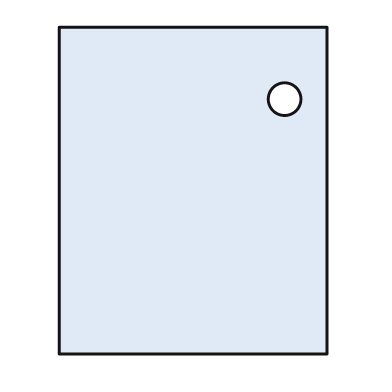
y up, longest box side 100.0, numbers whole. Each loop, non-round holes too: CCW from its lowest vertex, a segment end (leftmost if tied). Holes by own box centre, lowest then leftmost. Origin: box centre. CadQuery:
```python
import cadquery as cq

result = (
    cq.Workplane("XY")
    .moveTo(-41.0, -50.0)
    .lineTo(41.0, -50.0)
    .lineTo(41.0, 50.0)
    .lineTo(-41.0, 50.0)
    .close()
    .moveTo(28.0, 28.0)
    .circle(5.0)
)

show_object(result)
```